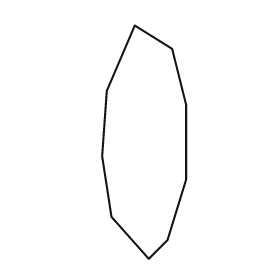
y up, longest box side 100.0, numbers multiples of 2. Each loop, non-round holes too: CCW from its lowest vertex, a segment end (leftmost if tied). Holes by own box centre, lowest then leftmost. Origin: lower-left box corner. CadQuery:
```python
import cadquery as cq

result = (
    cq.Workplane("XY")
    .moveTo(20.0, 0.0)
    .lineTo(28.0, 8.0)
    .lineTo(36.0, 34.0)
    .lineTo(36.0, 66.0)
    .lineTo(30.0, 90.0)
    .lineTo(14.0, 100.0)
    .lineTo(2.0, 72.0)
    .lineTo(0.0, 44.0)
    .lineTo(4.0, 18.0)
    .close()
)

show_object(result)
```